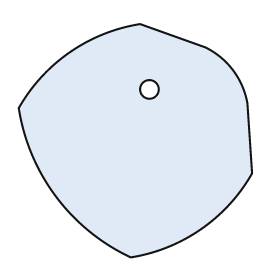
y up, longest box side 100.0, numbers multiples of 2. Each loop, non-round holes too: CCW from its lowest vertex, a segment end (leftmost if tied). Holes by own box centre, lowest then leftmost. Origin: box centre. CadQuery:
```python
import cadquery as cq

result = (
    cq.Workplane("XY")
    .moveTo(-2.0, -50.0)
    .threePointArc((28.0, -38.0), (50.0, -14.0))
    .lineTo(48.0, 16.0)
    .threePointArc((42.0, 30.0), (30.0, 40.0))
    .lineTo(2.0, 50.0)
    .threePointArc((-28.0, 38.0), (-50.0, 14.0))
    .threePointArc((-34.0, -24.0), (-2.0, -50.0))
    .close()
    .moveTo(6.0, 22.0)
    .circle(4.0)
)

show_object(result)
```